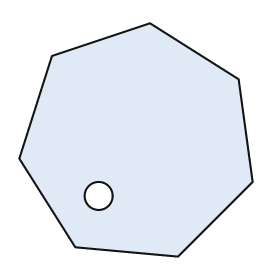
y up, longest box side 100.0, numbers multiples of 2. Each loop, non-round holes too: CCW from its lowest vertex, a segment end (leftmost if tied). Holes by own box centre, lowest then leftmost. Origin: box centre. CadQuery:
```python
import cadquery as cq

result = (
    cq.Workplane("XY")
    .moveTo(18.0, -50.0)
    .lineTo(50.0, -18.0)
    .lineTo(44.0, 26.0)
    .lineTo(6.0, 50.0)
    .lineTo(-36.0, 36.0)
    .lineTo(-50.0, -8.0)
    .lineTo(-26.0, -46.0)
    .close()
    .moveTo(-16.0, -24.0)
    .circle(6.0)
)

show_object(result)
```